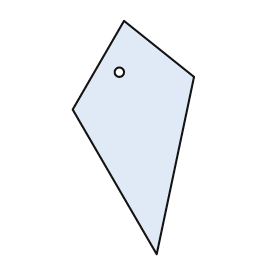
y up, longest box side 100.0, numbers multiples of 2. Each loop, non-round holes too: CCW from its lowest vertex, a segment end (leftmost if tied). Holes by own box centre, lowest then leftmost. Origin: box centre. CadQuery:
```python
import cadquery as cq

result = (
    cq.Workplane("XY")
    .moveTo(10.0, -50.0)
    .lineTo(26.0, 26.0)
    .lineTo(-4.0, 50.0)
    .lineTo(-26.0, 12.0)
    .close()
    .moveTo(-6.0, 28.0)
    .circle(2.0)
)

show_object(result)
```